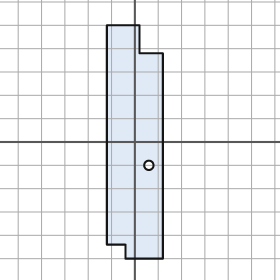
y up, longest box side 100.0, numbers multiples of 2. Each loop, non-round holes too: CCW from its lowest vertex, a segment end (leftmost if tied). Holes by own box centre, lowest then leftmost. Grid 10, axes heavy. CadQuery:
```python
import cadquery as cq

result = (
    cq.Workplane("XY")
    .moveTo(-4.0, -50.0)
    .lineTo(12.0, -50.0)
    .lineTo(12.0, 38.0)
    .lineTo(2.0, 38.0)
    .lineTo(2.0, 50.0)
    .lineTo(-12.0, 50.0)
    .lineTo(-12.0, -44.0)
    .lineTo(-4.0, -44.0)
    .close()
    .moveTo(6.0, -10.0)
    .circle(2.0)
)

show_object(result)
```